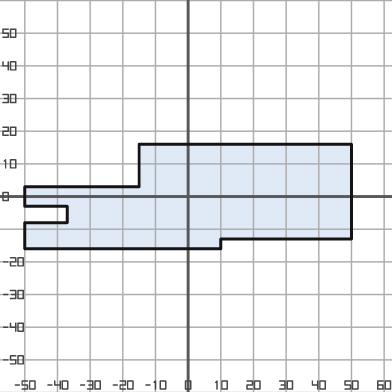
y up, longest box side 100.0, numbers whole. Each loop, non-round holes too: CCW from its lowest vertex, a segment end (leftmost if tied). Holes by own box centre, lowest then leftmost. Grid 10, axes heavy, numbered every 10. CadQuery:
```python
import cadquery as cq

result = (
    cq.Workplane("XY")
    .moveTo(-50.0, -16.0)
    .lineTo(10.0, -16.0)
    .lineTo(10.0, -13.0)
    .lineTo(50.0, -13.0)
    .lineTo(50.0, 16.0)
    .lineTo(-15.0, 16.0)
    .lineTo(-15.0, 3.0)
    .lineTo(-50.0, 3.0)
    .lineTo(-50.0, -3.0)
    .lineTo(-37.0, -3.0)
    .lineTo(-37.0, -8.0)
    .lineTo(-50.0, -8.0)
    .close()
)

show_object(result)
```